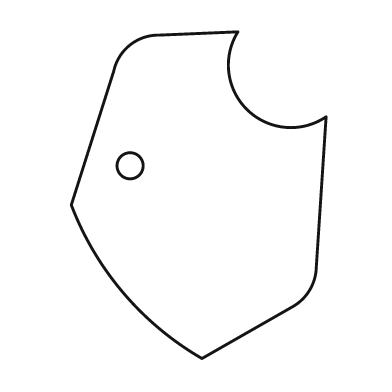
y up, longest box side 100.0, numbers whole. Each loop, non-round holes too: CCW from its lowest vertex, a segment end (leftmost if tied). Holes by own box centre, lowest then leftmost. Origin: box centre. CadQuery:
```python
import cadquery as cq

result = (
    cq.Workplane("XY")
    .moveTo(1.0, -50.0)
    .lineTo(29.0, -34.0)
    .threePointArc((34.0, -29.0), (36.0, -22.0))
    .lineTo(39.0, 24.0)
    .threePointArc((15.0, 26.0), (12.0, 50.0))
    .lineTo(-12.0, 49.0)
    .threePointArc((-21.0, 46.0), (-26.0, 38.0))
    .lineTo(-39.0, -3.0)
    .threePointArc((-23.0, -30.0), (1.0, -50.0))
    .close()
    .moveTo(-21.0, 9.0)
    .circle(4.0)
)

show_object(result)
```